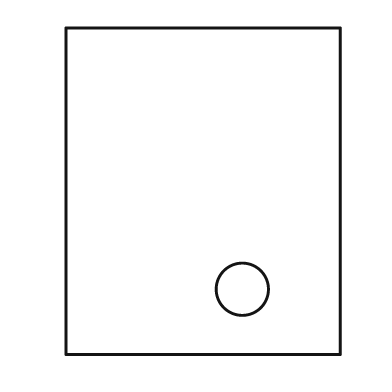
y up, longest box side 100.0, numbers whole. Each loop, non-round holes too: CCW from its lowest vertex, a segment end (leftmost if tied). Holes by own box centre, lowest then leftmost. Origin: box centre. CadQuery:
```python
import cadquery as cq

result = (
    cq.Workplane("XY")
    .moveTo(-42.0, -50.0)
    .lineTo(42.0, -50.0)
    .lineTo(42.0, 50.0)
    .lineTo(-42.0, 50.0)
    .close()
    .moveTo(12.0, -30.0)
    .circle(8.0)
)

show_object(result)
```